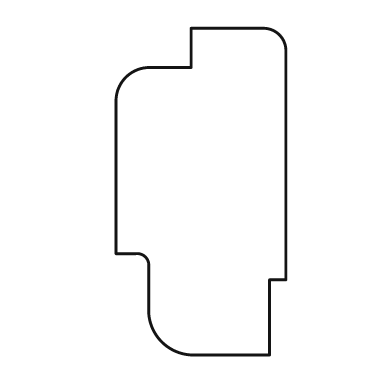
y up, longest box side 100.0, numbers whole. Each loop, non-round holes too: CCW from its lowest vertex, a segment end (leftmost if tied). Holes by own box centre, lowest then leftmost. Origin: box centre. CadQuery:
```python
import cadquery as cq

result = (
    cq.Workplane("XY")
    .moveTo(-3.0, -50.0)
    .lineTo(21.0, -50.0)
    .lineTo(21.0, -27.0)
    .lineTo(26.0, -27.0)
    .lineTo(26.0, 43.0)
    .threePointArc((24.0, 48.0), (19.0, 50.0))
    .lineTo(-3.0, 50.0)
    .lineTo(-3.0, 38.0)
    .lineTo(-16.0, 38.0)
    .threePointArc((-23.0, 35.0), (-26.0, 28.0))
    .lineTo(-26.0, -19.0)
    .lineTo(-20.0, -19.0)
    .threePointArc((-17.0, -20.0), (-16.0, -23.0))
    .lineTo(-16.0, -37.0)
    .threePointArc((-12.0, -46.0), (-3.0, -50.0))
    .close()
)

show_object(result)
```